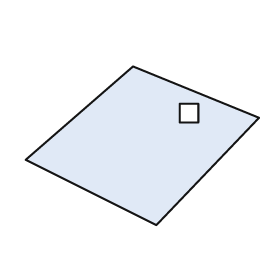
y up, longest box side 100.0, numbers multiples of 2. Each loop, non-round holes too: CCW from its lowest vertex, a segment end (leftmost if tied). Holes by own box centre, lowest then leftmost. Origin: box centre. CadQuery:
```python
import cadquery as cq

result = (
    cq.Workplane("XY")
    .moveTo(6.0, -34.0)
    .lineTo(50.0, 12.0)
    .lineTo(-4.0, 34.0)
    .lineTo(-50.0, -6.0)
    .close()
    .moveTo(16.0, 10.0)
    .lineTo(24.0, 10.0)
    .lineTo(24.0, 18.0)
    .lineTo(16.0, 18.0)
    .close()
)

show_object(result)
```